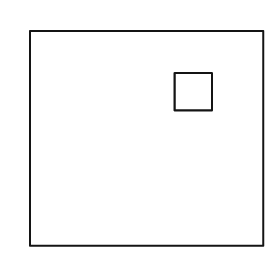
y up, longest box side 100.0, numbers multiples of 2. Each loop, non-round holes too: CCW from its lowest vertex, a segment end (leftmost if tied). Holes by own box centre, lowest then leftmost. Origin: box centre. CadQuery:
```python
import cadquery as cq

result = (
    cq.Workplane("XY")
    .moveTo(-50.0, -46.0)
    .lineTo(50.0, -46.0)
    .lineTo(50.0, 46.0)
    .lineTo(-50.0, 46.0)
    .close()
    .moveTo(12.0, 12.0)
    .lineTo(28.0, 12.0)
    .lineTo(28.0, 28.0)
    .lineTo(12.0, 28.0)
    .close()
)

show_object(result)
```